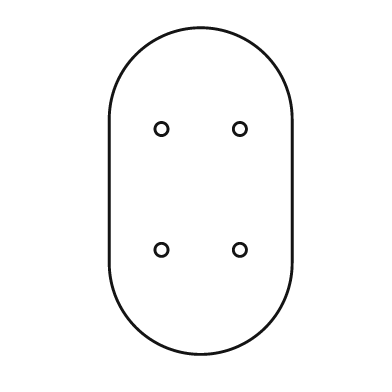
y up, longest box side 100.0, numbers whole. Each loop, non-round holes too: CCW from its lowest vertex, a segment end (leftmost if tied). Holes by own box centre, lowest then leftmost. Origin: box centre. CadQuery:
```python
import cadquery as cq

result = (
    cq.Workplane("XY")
    .moveTo(-28.0, -22.0)
    .threePointArc((0.0, -50.0), (28.0, -22.0))
    .lineTo(28.0, 22.0)
    .threePointArc((0.0, 50.0), (-28.0, 22.0))
    .close()
    .moveTo(-12.0, -18.0)
    .circle(2.0)
    .moveTo(12.0, -18.0)
    .circle(2.0)
    .moveTo(-12.0, 19.0)
    .circle(2.0)
    .moveTo(12.0, 19.0)
    .circle(2.0)
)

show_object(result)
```